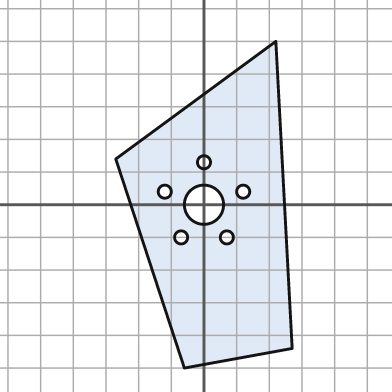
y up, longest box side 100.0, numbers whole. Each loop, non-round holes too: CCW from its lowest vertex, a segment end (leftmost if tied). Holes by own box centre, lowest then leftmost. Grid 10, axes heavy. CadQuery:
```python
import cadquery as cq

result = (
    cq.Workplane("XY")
    .moveTo(-6.0, -50.0)
    .lineTo(27.0, -44.0)
    .lineTo(22.0, 50.0)
    .lineTo(-27.0, 14.0)
    .close()
    .moveTo(-7.0, -10.0)
    .circle(2.0)
    .moveTo(7.0, -10.0)
    .circle(2.0)
    .moveTo(0.0, 0.0)
    .circle(6.0)
    .moveTo(-12.0, 4.0)
    .circle(2.0)
    .moveTo(12.0, 4.0)
    .circle(2.0)
    .moveTo(0.0, 13.0)
    .circle(2.0)
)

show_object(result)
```